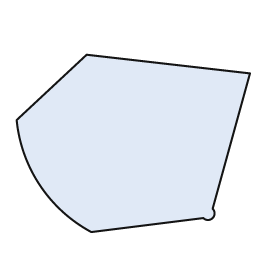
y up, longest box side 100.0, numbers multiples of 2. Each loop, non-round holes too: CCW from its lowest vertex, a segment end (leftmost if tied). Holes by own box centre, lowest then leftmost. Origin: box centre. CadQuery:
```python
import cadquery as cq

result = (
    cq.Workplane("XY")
    .moveTo(-18.0, -38.0)
    .lineTo(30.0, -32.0)
    .threePointArc((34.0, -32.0), (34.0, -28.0))
    .lineTo(50.0, 30.0)
    .lineTo(-20.0, 38.0)
    .lineTo(-50.0, 10.0)
    .threePointArc((-40.0, -18.0), (-18.0, -38.0))
    .close()
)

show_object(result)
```